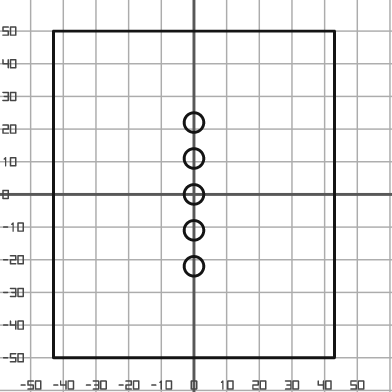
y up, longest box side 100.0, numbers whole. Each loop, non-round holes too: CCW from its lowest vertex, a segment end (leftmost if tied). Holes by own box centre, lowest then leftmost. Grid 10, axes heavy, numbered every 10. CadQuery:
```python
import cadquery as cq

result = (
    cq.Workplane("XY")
    .moveTo(-43.0, -50.0)
    .lineTo(43.0, -50.0)
    .lineTo(43.0, 50.0)
    .lineTo(-43.0, 50.0)
    .close()
    .moveTo(0.0, -22.0)
    .circle(3.0)
    .moveTo(0.0, -11.0)
    .circle(3.0)
    .moveTo(0.0, 0.0)
    .circle(3.0)
    .moveTo(0.0, 11.0)
    .circle(3.0)
    .moveTo(0.0, 22.0)
    .circle(3.0)
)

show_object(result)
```